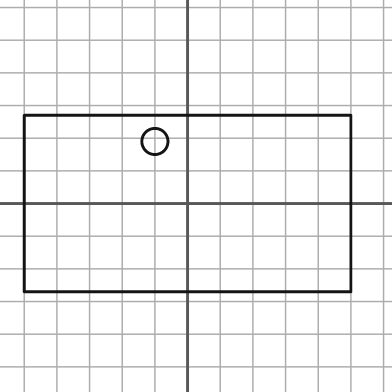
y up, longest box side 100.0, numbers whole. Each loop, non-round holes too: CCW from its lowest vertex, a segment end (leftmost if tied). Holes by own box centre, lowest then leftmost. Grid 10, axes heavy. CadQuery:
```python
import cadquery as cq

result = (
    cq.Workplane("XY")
    .moveTo(-50.0, -27.0)
    .lineTo(50.0, -27.0)
    .lineTo(50.0, 27.0)
    .lineTo(-50.0, 27.0)
    .close()
    .moveTo(-10.0, 19.0)
    .circle(4.0)
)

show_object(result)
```